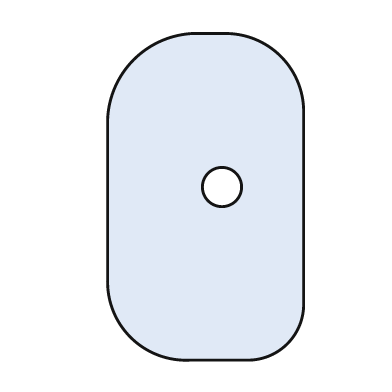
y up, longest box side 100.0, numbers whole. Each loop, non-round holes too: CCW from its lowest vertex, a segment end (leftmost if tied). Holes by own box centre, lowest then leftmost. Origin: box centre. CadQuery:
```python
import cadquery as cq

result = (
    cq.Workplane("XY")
    .moveTo(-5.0, -50.0)
    .lineTo(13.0, -50.0)
    .threePointArc((25.0, -45.0), (30.0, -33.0))
    .lineTo(30.0, 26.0)
    .threePointArc((23.0, 43.0), (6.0, 50.0))
    .lineTo(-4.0, 50.0)
    .threePointArc((-22.0, 42.0), (-30.0, 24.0))
    .lineTo(-30.0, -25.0)
    .threePointArc((-23.0, -43.0), (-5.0, -50.0))
    .close()
    .moveTo(5.0, 3.0)
    .circle(6.0)
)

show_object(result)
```